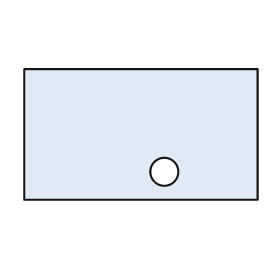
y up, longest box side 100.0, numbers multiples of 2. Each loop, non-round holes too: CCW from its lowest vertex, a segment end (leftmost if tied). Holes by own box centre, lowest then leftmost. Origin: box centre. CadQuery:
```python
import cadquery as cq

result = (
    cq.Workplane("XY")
    .moveTo(-50.0, -28.0)
    .lineTo(50.0, -28.0)
    .lineTo(50.0, 28.0)
    .lineTo(-50.0, 28.0)
    .close()
    .moveTo(10.0, -16.0)
    .circle(6.0)
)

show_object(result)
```